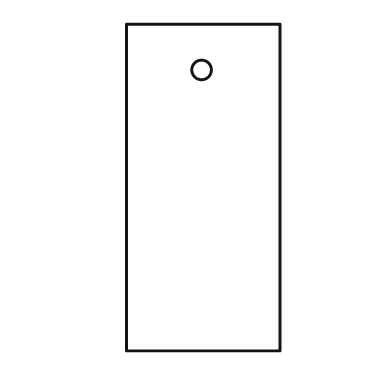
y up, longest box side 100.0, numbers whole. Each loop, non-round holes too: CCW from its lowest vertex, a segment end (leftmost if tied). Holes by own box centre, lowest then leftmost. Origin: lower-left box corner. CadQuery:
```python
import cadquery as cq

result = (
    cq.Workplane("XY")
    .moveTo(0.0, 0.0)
    .lineTo(47.0, 0.0)
    .lineTo(47.0, 100.0)
    .lineTo(0.0, 100.0)
    .close()
    .moveTo(23.0, 86.0)
    .circle(3.0)
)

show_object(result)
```